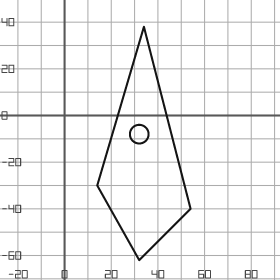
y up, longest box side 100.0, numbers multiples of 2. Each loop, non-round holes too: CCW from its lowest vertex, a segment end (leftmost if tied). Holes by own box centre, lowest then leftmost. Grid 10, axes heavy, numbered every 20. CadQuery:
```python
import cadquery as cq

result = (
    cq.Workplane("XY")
    .moveTo(32.0, -62.0)
    .lineTo(54.0, -40.0)
    .lineTo(34.0, 38.0)
    .lineTo(14.0, -30.0)
    .close()
    .moveTo(32.0, -8.0)
    .circle(4.0)
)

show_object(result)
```